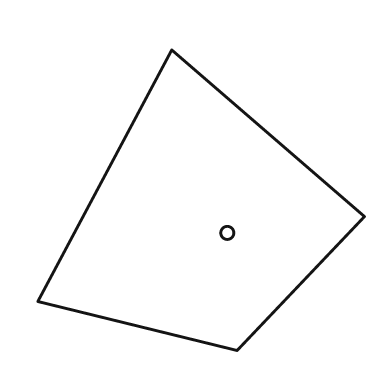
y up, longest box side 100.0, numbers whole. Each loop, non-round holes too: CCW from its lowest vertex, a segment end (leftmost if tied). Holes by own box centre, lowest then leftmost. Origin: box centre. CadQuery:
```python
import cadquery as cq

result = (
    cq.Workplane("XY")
    .moveTo(11.0, -46.0)
    .lineTo(50.0, -5.0)
    .lineTo(-9.0, 46.0)
    .lineTo(-50.0, -31.0)
    .close()
    .moveTo(8.0, -10.0)
    .circle(2.0)
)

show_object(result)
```